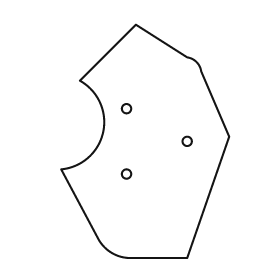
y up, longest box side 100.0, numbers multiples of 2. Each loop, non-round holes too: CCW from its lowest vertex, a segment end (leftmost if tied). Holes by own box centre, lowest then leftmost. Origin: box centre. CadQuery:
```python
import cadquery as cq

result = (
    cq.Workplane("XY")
    .moveTo(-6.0, -50.0)
    .lineTo(18.0, -50.0)
    .lineTo(36.0, 2.0)
    .lineTo(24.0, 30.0)
    .threePointArc((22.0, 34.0), (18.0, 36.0))
    .lineTo(-4.0, 50.0)
    .lineTo(-28.0, 26.0)
    .threePointArc((-18.0, 4.0), (-36.0, -12.0))
    .lineTo(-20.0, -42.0)
    .threePointArc((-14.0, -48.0), (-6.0, -50.0))
    .close()
    .moveTo(-8.0, -14.0)
    .circle(2.0)
    .moveTo(18.0, 0.0)
    .circle(2.0)
    .moveTo(-8.0, 14.0)
    .circle(2.0)
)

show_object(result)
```